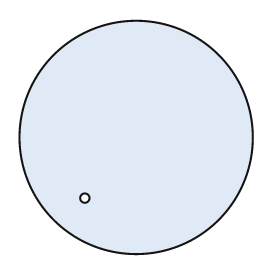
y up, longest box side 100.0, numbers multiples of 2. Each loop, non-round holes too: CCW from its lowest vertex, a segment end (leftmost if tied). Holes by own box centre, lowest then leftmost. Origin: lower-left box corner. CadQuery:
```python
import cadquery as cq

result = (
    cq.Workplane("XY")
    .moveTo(50.0, 50.0)
    .circle(50.0)
    .moveTo(28.0, 24.0)
    .circle(2.0)
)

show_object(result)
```